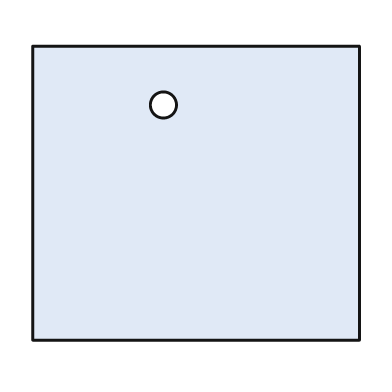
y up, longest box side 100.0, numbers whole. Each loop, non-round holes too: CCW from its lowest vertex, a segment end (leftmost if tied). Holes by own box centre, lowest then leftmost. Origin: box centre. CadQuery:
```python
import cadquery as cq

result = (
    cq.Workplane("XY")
    .moveTo(-50.0, -45.0)
    .lineTo(50.0, -45.0)
    .lineTo(50.0, 45.0)
    .lineTo(-50.0, 45.0)
    .close()
    .moveTo(-10.0, 27.0)
    .circle(4.0)
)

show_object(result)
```